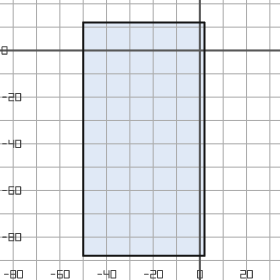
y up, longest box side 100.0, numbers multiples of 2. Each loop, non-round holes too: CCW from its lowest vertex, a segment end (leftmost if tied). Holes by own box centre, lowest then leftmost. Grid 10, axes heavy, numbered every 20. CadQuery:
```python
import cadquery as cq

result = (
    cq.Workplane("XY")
    .moveTo(-50.0, -88.0)
    .lineTo(2.0, -88.0)
    .lineTo(2.0, 12.0)
    .lineTo(-50.0, 12.0)
    .close()
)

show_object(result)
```